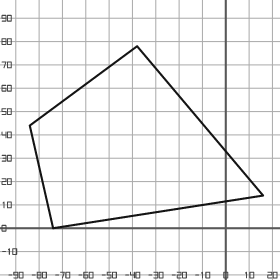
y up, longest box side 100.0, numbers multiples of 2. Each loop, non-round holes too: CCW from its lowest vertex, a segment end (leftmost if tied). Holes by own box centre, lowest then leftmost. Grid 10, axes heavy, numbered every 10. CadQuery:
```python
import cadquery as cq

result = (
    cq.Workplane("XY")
    .moveTo(-74.0, 0.0)
    .lineTo(16.0, 14.0)
    .lineTo(-38.0, 78.0)
    .lineTo(-84.0, 44.0)
    .close()
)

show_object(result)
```